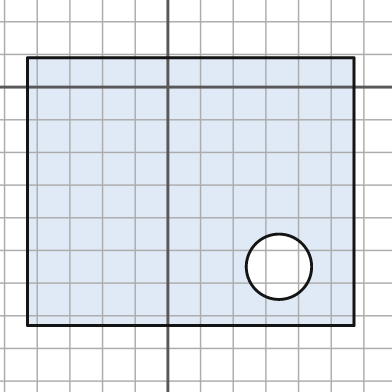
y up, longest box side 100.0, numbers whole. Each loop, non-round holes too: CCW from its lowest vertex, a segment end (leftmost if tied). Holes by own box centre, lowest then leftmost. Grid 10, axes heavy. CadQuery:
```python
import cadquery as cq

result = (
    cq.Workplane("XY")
    .moveTo(-43.0, -73.0)
    .lineTo(57.0, -73.0)
    .lineTo(57.0, 9.0)
    .lineTo(-43.0, 9.0)
    .close()
    .moveTo(34.0, -55.0)
    .circle(10.0)
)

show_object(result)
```